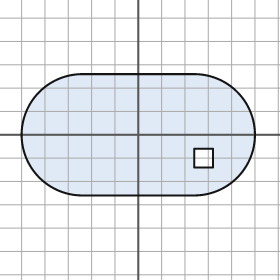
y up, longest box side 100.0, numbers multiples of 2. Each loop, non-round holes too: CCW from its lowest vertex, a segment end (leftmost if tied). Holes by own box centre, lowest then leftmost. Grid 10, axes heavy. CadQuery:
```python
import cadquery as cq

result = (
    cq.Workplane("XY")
    .moveTo(-24.0, -26.0)
    .lineTo(24.0, -26.0)
    .threePointArc((50.0, 0.0), (24.0, 26.0))
    .lineTo(-24.0, 26.0)
    .threePointArc((-50.0, 0.0), (-24.0, -26.0))
    .close()
    .moveTo(24.0, -14.0)
    .lineTo(32.0, -14.0)
    .lineTo(32.0, -6.0)
    .lineTo(24.0, -6.0)
    .close()
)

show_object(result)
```